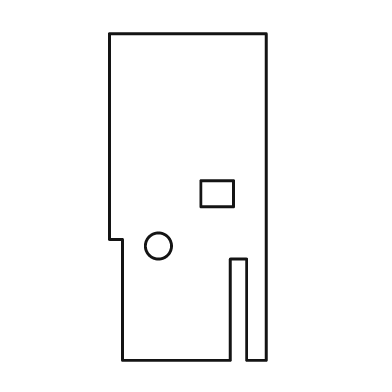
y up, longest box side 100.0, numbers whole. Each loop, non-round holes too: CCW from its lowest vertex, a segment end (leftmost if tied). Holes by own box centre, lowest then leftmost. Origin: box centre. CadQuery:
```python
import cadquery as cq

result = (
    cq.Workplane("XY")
    .moveTo(-20.0, -50.0)
    .lineTo(13.0, -50.0)
    .lineTo(13.0, -19.0)
    .lineTo(18.0, -19.0)
    .lineTo(18.0, -50.0)
    .lineTo(24.0, -50.0)
    .lineTo(24.0, 50.0)
    .lineTo(-24.0, 50.0)
    .lineTo(-24.0, -13.0)
    .lineTo(-20.0, -13.0)
    .close()
    .moveTo(-9.0, -15.0)
    .circle(4.0)
    .moveTo(4.0, -3.0)
    .lineTo(14.0, -3.0)
    .lineTo(14.0, 5.0)
    .lineTo(4.0, 5.0)
    .close()
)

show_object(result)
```